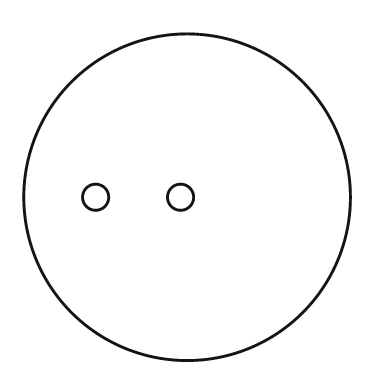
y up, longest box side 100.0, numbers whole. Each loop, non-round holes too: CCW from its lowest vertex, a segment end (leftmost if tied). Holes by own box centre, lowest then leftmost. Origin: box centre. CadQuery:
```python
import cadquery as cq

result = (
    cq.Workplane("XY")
    .moveTo(0.0, 0.0)
    .circle(50.0)
    .moveTo(-28.0, 0.0)
    .circle(4.0)
    .moveTo(-2.0, 0.0)
    .circle(4.0)
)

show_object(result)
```